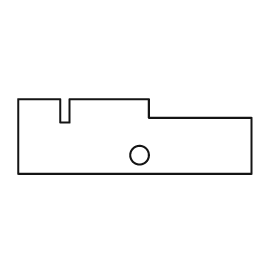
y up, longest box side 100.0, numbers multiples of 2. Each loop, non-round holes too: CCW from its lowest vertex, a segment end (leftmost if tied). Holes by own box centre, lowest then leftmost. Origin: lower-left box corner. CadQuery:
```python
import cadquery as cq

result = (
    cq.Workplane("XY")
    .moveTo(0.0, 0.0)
    .lineTo(100.0, 0.0)
    .lineTo(100.0, 24.0)
    .lineTo(56.0, 24.0)
    .lineTo(56.0, 32.0)
    .lineTo(22.0, 32.0)
    .lineTo(22.0, 22.0)
    .lineTo(18.0, 22.0)
    .lineTo(18.0, 32.0)
    .lineTo(0.0, 32.0)
    .close()
    .moveTo(52.0, 8.0)
    .circle(4.0)
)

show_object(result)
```